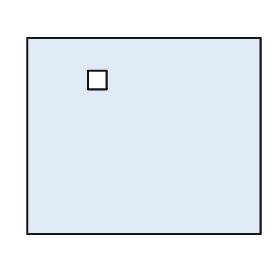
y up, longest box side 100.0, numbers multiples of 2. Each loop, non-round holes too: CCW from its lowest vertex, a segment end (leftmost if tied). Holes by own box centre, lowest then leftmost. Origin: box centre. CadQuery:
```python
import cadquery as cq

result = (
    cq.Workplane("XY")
    .moveTo(-50.0, -42.0)
    .lineTo(50.0, -42.0)
    .lineTo(50.0, 42.0)
    .lineTo(-50.0, 42.0)
    .close()
    .moveTo(-24.0, 20.0)
    .lineTo(-16.0, 20.0)
    .lineTo(-16.0, 28.0)
    .lineTo(-24.0, 28.0)
    .close()
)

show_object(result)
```